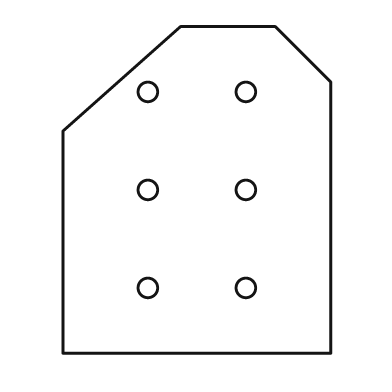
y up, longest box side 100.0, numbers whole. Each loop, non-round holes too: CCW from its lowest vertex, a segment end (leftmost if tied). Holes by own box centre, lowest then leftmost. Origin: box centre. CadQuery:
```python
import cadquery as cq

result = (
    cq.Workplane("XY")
    .moveTo(-41.0, -50.0)
    .lineTo(41.0, -50.0)
    .lineTo(41.0, 33.0)
    .lineTo(24.0, 50.0)
    .lineTo(-5.0, 50.0)
    .lineTo(-41.0, 18.0)
    .close()
    .moveTo(-15.0, -30.0)
    .circle(3.0)
    .moveTo(15.0, -30.0)
    .circle(3.0)
    .moveTo(-15.0, 0.0)
    .circle(3.0)
    .moveTo(15.0, 0.0)
    .circle(3.0)
    .moveTo(-15.0, 30.0)
    .circle(3.0)
    .moveTo(15.0, 30.0)
    .circle(3.0)
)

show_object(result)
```